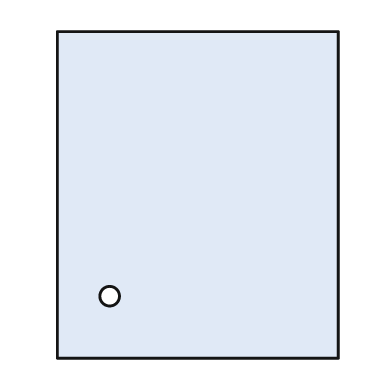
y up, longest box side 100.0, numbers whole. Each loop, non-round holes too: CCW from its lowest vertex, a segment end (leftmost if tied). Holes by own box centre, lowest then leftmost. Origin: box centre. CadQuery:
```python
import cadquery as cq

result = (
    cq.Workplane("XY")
    .moveTo(-43.0, -50.0)
    .lineTo(43.0, -50.0)
    .lineTo(43.0, 50.0)
    .lineTo(-43.0, 50.0)
    .close()
    .moveTo(-27.0, -31.0)
    .circle(3.0)
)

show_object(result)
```